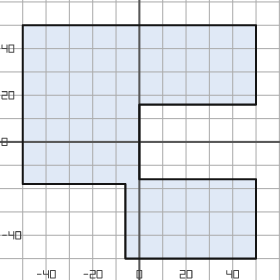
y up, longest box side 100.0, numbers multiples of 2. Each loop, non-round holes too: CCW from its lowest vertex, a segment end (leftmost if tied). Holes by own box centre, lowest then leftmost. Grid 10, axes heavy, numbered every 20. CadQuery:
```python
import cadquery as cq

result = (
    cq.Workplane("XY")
    .moveTo(-6.0, -50.0)
    .lineTo(50.0, -50.0)
    .lineTo(50.0, -16.0)
    .lineTo(0.0, -16.0)
    .lineTo(0.0, 16.0)
    .lineTo(50.0, 16.0)
    .lineTo(50.0, 50.0)
    .lineTo(-50.0, 50.0)
    .lineTo(-50.0, -18.0)
    .lineTo(-6.0, -18.0)
    .close()
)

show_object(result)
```